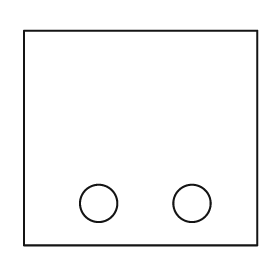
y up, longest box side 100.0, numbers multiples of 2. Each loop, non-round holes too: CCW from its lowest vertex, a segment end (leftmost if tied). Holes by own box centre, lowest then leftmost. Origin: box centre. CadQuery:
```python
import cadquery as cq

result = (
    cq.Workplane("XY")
    .moveTo(-50.0, -46.0)
    .lineTo(50.0, -46.0)
    .lineTo(50.0, 46.0)
    .lineTo(-50.0, 46.0)
    .close()
    .moveTo(-18.0, -28.0)
    .circle(8.0)
    .moveTo(22.0, -28.0)
    .circle(8.0)
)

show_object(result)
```